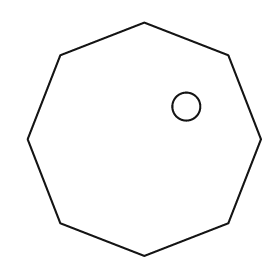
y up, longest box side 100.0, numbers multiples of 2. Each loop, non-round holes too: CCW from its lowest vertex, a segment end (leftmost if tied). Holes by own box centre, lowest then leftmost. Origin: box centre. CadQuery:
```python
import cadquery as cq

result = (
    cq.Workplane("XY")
    .moveTo(0.0, -50.0)
    .lineTo(36.0, -36.0)
    .lineTo(50.0, 0.0)
    .lineTo(36.0, 36.0)
    .lineTo(0.0, 50.0)
    .lineTo(-36.0, 36.0)
    .lineTo(-50.0, 0.0)
    .lineTo(-36.0, -36.0)
    .close()
    .moveTo(18.0, 14.0)
    .circle(6.0)
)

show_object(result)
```